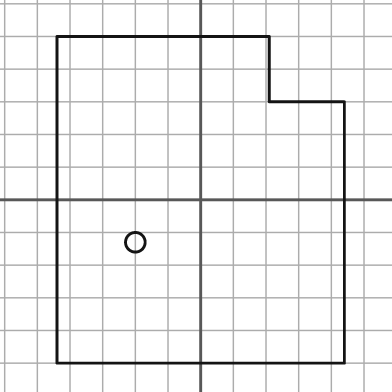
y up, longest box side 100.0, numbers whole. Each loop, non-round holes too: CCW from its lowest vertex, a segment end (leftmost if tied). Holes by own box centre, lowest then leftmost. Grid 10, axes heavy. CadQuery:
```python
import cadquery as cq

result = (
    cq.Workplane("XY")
    .moveTo(-44.0, -50.0)
    .lineTo(44.0, -50.0)
    .lineTo(44.0, 30.0)
    .lineTo(21.0, 30.0)
    .lineTo(21.0, 50.0)
    .lineTo(-44.0, 50.0)
    .close()
    .moveTo(-20.0, -13.0)
    .circle(3.0)
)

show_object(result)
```